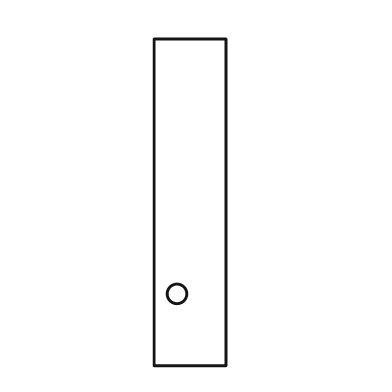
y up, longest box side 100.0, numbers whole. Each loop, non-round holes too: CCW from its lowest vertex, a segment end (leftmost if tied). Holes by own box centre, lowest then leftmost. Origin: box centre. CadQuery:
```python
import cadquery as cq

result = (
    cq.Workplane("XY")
    .moveTo(-11.0, -50.0)
    .lineTo(11.0, -50.0)
    .lineTo(11.0, 50.0)
    .lineTo(-11.0, 50.0)
    .close()
    .moveTo(-4.0, -28.0)
    .circle(3.0)
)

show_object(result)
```